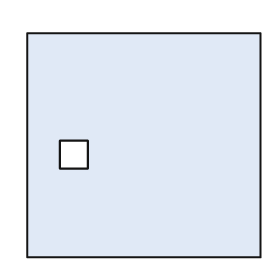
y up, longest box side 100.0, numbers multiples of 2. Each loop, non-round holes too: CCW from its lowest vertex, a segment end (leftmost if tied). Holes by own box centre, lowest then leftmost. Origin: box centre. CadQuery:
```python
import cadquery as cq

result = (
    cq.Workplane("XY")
    .moveTo(-50.0, -48.0)
    .lineTo(50.0, -48.0)
    .lineTo(50.0, 48.0)
    .lineTo(-50.0, 48.0)
    .close()
    .moveTo(-36.0, -10.0)
    .lineTo(-24.0, -10.0)
    .lineTo(-24.0, 2.0)
    .lineTo(-36.0, 2.0)
    .close()
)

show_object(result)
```